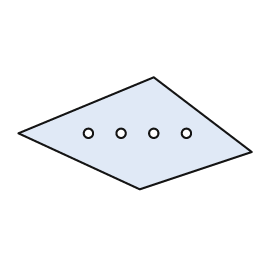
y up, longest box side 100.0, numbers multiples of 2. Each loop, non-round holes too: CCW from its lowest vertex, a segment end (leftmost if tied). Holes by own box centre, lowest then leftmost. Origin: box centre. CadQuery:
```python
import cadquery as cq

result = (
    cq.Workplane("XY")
    .moveTo(2.0, -24.0)
    .lineTo(50.0, -8.0)
    .lineTo(8.0, 24.0)
    .lineTo(-50.0, 0.0)
    .close()
    .moveTo(-20.0, 0.0)
    .circle(2.0)
    .moveTo(-6.0, 0.0)
    .circle(2.0)
    .moveTo(8.0, 0.0)
    .circle(2.0)
    .moveTo(22.0, 0.0)
    .circle(2.0)
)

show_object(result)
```